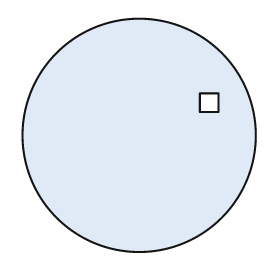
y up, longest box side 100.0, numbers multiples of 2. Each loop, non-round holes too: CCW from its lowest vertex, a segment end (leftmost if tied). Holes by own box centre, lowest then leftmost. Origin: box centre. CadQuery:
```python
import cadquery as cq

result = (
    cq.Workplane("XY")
    .moveTo(0.0, 0.0)
    .circle(50.0)
    .moveTo(26.0, 10.0)
    .lineTo(34.0, 10.0)
    .lineTo(34.0, 18.0)
    .lineTo(26.0, 18.0)
    .close()
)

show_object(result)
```